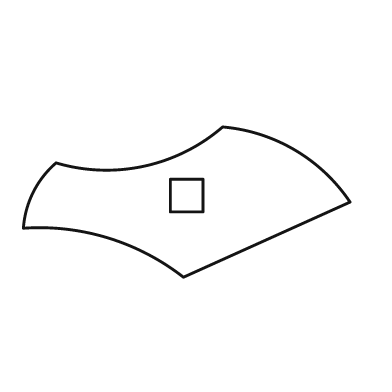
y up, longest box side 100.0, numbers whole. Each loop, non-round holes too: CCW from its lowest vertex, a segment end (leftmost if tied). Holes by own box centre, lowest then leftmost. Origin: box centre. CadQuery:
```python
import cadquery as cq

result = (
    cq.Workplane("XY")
    .moveTo(-1.0, -23.0)
    .lineTo(50.0, 0.0)
    .threePointArc((33.0, 16.0), (11.0, 23.0))
    .threePointArc((-13.0, 11.0), (-40.0, 12.0))
    .threePointArc((-47.0, 3.0), (-50.0, -8.0))
    .threePointArc((-24.0, -11.0), (-1.0, -23.0))
    .close()
    .moveTo(-5.0, -3.0)
    .lineTo(5.0, -3.0)
    .lineTo(5.0, 7.0)
    .lineTo(-5.0, 7.0)
    .close()
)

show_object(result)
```